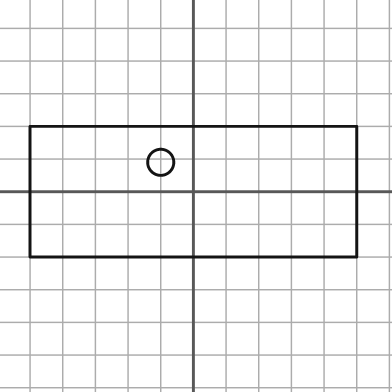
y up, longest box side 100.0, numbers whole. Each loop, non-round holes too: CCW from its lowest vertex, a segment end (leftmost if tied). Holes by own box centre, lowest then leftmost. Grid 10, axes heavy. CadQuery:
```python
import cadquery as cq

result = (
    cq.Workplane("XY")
    .moveTo(-50.0, -20.0)
    .lineTo(50.0, -20.0)
    .lineTo(50.0, 20.0)
    .lineTo(-50.0, 20.0)
    .close()
    .moveTo(-10.0, 9.0)
    .circle(4.0)
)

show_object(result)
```